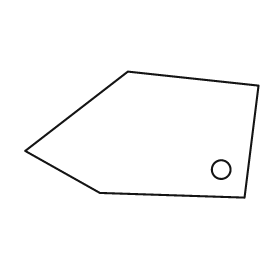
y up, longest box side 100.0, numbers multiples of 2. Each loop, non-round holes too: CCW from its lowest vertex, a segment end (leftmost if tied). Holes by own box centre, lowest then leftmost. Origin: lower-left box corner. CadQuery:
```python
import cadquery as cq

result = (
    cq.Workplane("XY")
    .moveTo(94.0, 0.0)
    .lineTo(100.0, 48.0)
    .lineTo(44.0, 54.0)
    .lineTo(0.0, 20.0)
    .lineTo(32.0, 2.0)
    .close()
    .moveTo(84.0, 12.0)
    .circle(4.0)
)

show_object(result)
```